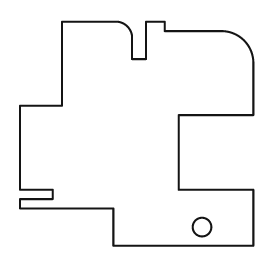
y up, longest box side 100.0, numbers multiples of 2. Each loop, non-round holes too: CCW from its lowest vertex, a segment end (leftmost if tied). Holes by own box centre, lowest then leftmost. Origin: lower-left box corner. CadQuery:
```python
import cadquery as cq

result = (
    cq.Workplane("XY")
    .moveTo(40.0, 0.0)
    .lineTo(100.0, 0.0)
    .lineTo(100.0, 24.0)
    .lineTo(68.0, 24.0)
    .lineTo(68.0, 56.0)
    .lineTo(100.0, 56.0)
    .lineTo(100.0, 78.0)
    .threePointArc((96.0, 88.0), (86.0, 92.0))
    .lineTo(62.0, 92.0)
    .lineTo(62.0, 96.0)
    .lineTo(54.0, 96.0)
    .lineTo(54.0, 80.0)
    .lineTo(48.0, 80.0)
    .lineTo(48.0, 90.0)
    .threePointArc((46.0, 94.0), (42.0, 96.0))
    .lineTo(18.0, 96.0)
    .lineTo(18.0, 60.0)
    .lineTo(0.0, 60.0)
    .lineTo(0.0, 24.0)
    .lineTo(14.0, 24.0)
    .lineTo(14.0, 20.0)
    .lineTo(0.0, 20.0)
    .lineTo(0.0, 16.0)
    .lineTo(40.0, 16.0)
    .close()
    .moveTo(78.0, 8.0)
    .circle(4.0)
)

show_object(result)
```